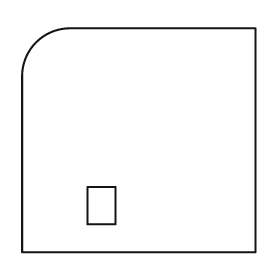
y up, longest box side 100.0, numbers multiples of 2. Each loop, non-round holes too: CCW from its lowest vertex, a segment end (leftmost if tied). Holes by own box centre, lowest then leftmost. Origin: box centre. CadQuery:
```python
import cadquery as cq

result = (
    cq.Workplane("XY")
    .moveTo(-50.0, -48.0)
    .lineTo(50.0, -48.0)
    .lineTo(50.0, 48.0)
    .lineTo(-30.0, 48.0)
    .threePointArc((-44.0, 42.0), (-50.0, 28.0))
    .close()
    .moveTo(-22.0, -36.0)
    .lineTo(-10.0, -36.0)
    .lineTo(-10.0, -20.0)
    .lineTo(-22.0, -20.0)
    .close()
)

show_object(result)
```